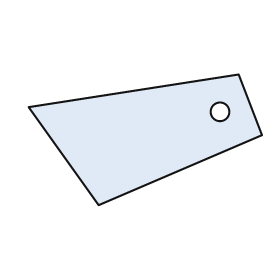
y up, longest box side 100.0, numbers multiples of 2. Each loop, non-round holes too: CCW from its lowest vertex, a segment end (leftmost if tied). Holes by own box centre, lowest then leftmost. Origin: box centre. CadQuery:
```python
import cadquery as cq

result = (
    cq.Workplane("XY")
    .moveTo(-20.0, -28.0)
    .lineTo(50.0, 2.0)
    .lineTo(40.0, 28.0)
    .lineTo(-50.0, 14.0)
    .close()
    .moveTo(32.0, 12.0)
    .circle(4.0)
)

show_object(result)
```